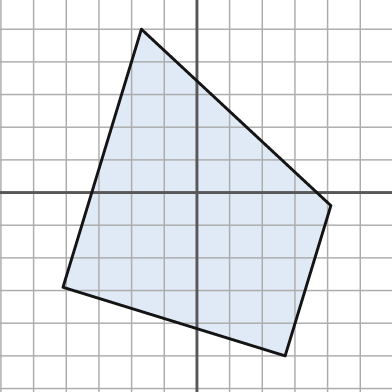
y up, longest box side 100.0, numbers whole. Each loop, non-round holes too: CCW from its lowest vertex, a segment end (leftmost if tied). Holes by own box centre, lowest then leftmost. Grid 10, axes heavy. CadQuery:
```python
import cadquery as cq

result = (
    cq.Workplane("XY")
    .moveTo(27.0, -50.0)
    .lineTo(41.0, -4.0)
    .lineTo(-17.0, 50.0)
    .lineTo(-41.0, -29.0)
    .close()
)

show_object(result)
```